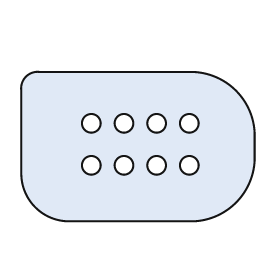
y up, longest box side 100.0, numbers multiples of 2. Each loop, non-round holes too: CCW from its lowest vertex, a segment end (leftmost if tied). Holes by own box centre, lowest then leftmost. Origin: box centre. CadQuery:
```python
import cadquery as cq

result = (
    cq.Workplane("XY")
    .moveTo(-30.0, -32.0)
    .lineTo(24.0, -32.0)
    .threePointArc((42.0, -24.0), (50.0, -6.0))
    .lineTo(50.0, 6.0)
    .threePointArc((42.0, 24.0), (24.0, 32.0))
    .lineTo(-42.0, 32.0)
    .threePointArc((-48.0, 30.0), (-50.0, 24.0))
    .lineTo(-50.0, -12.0)
    .threePointArc((-44.0, -26.0), (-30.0, -32.0))
    .close()
    .moveTo(-20.0, -8.0)
    .circle(4.0)
    .moveTo(-6.0, -8.0)
    .circle(4.0)
    .moveTo(8.0, -8.0)
    .circle(4.0)
    .moveTo(22.0, -8.0)
    .circle(4.0)
    .moveTo(-20.0, 10.0)
    .circle(4.0)
    .moveTo(-6.0, 10.0)
    .circle(4.0)
    .moveTo(8.0, 10.0)
    .circle(4.0)
    .moveTo(22.0, 10.0)
    .circle(4.0)
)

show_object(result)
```